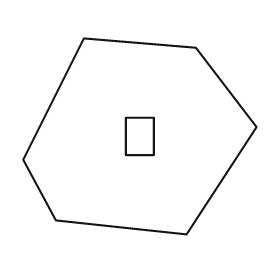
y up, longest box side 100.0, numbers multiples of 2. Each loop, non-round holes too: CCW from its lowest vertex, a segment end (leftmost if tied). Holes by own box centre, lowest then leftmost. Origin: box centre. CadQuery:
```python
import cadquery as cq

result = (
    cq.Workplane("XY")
    .moveTo(20.0, -42.0)
    .lineTo(50.0, 4.0)
    .lineTo(24.0, 38.0)
    .lineTo(-24.0, 42.0)
    .lineTo(-50.0, -10.0)
    .lineTo(-36.0, -36.0)
    .close()
    .moveTo(-6.0, -8.0)
    .lineTo(6.0, -8.0)
    .lineTo(6.0, 8.0)
    .lineTo(-6.0, 8.0)
    .close()
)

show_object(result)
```